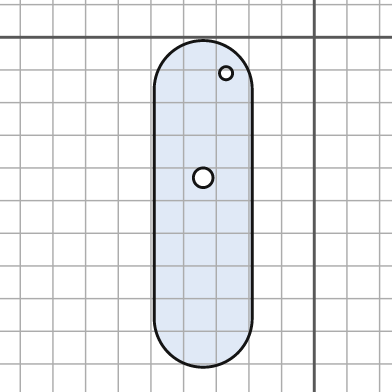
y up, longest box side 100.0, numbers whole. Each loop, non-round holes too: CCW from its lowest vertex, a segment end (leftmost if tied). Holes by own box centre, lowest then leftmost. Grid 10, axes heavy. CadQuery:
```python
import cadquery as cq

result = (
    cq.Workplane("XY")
    .moveTo(-49.0, -86.0)
    .threePointArc((-34.0, -101.0), (-19.0, -86.0))
    .lineTo(-19.0, -16.0)
    .threePointArc((-34.0, -1.0), (-49.0, -16.0))
    .close()
    .moveTo(-34.0, -43.0)
    .circle(3.0)
    .moveTo(-27.0, -11.0)
    .circle(2.0)
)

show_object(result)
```